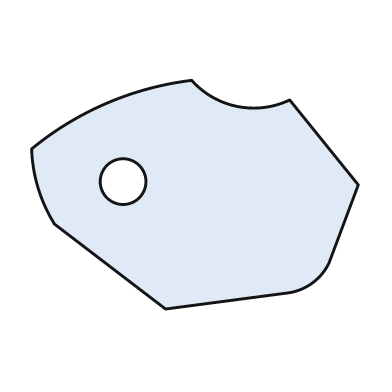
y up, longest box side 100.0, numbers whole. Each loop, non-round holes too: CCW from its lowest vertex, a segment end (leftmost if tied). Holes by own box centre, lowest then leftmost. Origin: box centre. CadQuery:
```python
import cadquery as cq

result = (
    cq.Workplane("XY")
    .moveTo(-9.0, -35.0)
    .lineTo(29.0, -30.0)
    .threePointArc((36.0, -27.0), (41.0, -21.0))
    .lineTo(50.0, 3.0)
    .lineTo(29.0, 29.0)
    .threePointArc((13.0, 27.0), (-1.0, 35.0))
    .threePointArc((-27.0, 28.0), (-50.0, 14.0))
    .threePointArc((-48.0, 2.0), (-43.0, -9.0))
    .close()
    .moveTo(-22.0, 4.0)
    .circle(7.0)
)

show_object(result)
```